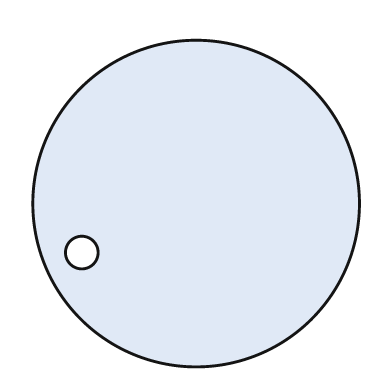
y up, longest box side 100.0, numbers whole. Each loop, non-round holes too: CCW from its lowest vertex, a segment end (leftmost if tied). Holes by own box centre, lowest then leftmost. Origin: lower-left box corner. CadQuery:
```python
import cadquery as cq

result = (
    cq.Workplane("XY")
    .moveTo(50.0, 50.0)
    .circle(50.0)
    .moveTo(15.0, 35.0)
    .circle(5.0)
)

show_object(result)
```